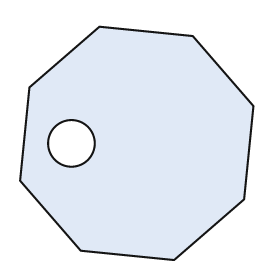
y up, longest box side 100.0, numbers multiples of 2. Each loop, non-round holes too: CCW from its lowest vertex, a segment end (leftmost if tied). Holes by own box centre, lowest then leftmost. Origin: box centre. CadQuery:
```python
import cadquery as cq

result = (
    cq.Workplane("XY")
    .moveTo(16.0, -50.0)
    .lineTo(46.0, -24.0)
    .lineTo(50.0, 16.0)
    .lineTo(24.0, 46.0)
    .lineTo(-16.0, 50.0)
    .lineTo(-46.0, 24.0)
    .lineTo(-50.0, -16.0)
    .lineTo(-24.0, -46.0)
    .close()
    .moveTo(-28.0, 0.0)
    .circle(10.0)
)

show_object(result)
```